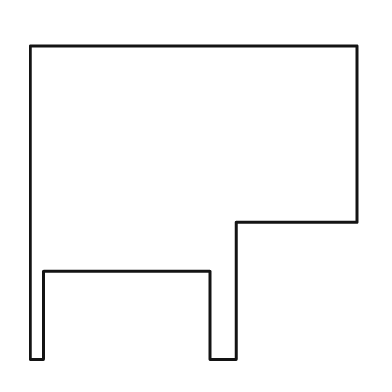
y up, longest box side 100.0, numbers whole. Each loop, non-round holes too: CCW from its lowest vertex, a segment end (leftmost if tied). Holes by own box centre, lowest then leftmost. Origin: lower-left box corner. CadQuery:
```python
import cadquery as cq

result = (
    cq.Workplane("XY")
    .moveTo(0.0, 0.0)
    .lineTo(4.0, 0.0)
    .lineTo(4.0, 27.0)
    .lineTo(55.0, 27.0)
    .lineTo(55.0, 0.0)
    .lineTo(63.0, 0.0)
    .lineTo(63.0, 42.0)
    .lineTo(100.0, 42.0)
    .lineTo(100.0, 96.0)
    .lineTo(0.0, 96.0)
    .close()
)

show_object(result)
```